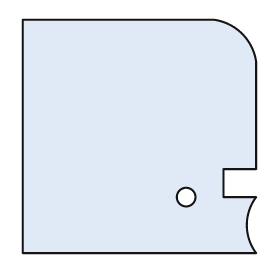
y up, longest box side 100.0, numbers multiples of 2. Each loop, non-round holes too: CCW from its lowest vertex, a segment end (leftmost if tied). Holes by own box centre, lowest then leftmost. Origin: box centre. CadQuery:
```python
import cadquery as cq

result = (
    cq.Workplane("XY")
    .moveTo(-50.0, -50.0)
    .lineTo(50.0, -50.0)
    .threePointArc((46.0, -38.0), (50.0, -26.0))
    .lineTo(36.0, -26.0)
    .lineTo(36.0, -14.0)
    .lineTo(50.0, -14.0)
    .lineTo(50.0, 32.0)
    .threePointArc((44.0, 44.0), (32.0, 50.0))
    .lineTo(-50.0, 50.0)
    .close()
    .moveTo(20.0, -26.0)
    .circle(4.0)
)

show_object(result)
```